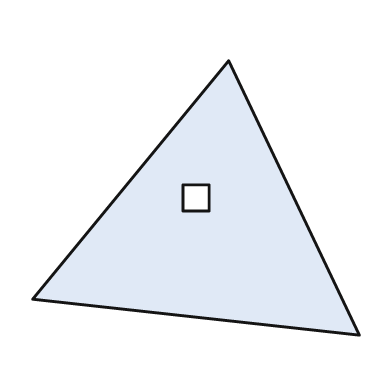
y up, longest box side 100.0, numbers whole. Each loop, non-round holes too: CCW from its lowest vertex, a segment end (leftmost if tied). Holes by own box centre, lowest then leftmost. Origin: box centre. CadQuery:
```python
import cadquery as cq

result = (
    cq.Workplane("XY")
    .moveTo(50.0, -42.0)
    .lineTo(10.0, 42.0)
    .lineTo(-50.0, -31.0)
    .close()
    .moveTo(-4.0, -4.0)
    .lineTo(4.0, -4.0)
    .lineTo(4.0, 4.0)
    .lineTo(-4.0, 4.0)
    .close()
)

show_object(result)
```